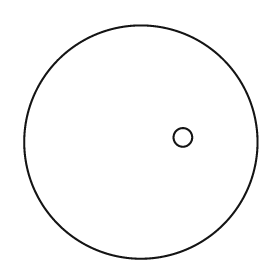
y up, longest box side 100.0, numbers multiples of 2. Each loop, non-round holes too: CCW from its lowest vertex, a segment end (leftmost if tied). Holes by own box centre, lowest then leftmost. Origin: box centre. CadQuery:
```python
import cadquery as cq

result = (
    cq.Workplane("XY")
    .moveTo(0.0, 0.0)
    .circle(50.0)
    .moveTo(18.0, 2.0)
    .circle(4.0)
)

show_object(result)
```